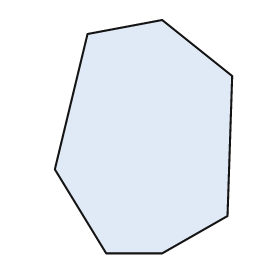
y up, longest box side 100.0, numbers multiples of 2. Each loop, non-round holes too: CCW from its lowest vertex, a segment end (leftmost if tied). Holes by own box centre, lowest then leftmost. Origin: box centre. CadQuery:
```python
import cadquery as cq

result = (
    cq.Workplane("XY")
    .moveTo(-16.0, -50.0)
    .lineTo(8.0, -50.0)
    .lineTo(36.0, -34.0)
    .lineTo(38.0, 26.0)
    .lineTo(8.0, 50.0)
    .lineTo(-24.0, 44.0)
    .lineTo(-38.0, -14.0)
    .close()
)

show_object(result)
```